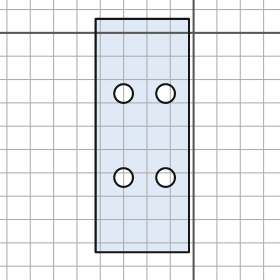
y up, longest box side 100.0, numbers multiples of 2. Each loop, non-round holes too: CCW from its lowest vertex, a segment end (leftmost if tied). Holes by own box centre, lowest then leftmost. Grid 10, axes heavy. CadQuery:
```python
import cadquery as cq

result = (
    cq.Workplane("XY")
    .moveTo(-42.0, -94.0)
    .lineTo(-2.0, -94.0)
    .lineTo(-2.0, 6.0)
    .lineTo(-42.0, 6.0)
    .close()
    .moveTo(-30.0, -62.0)
    .circle(4.0)
    .moveTo(-12.0, -62.0)
    .circle(4.0)
    .moveTo(-30.0, -26.0)
    .circle(4.0)
    .moveTo(-12.0, -26.0)
    .circle(4.0)
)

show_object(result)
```